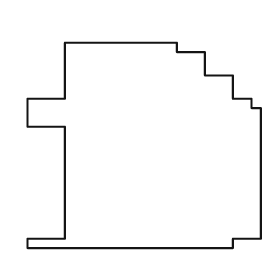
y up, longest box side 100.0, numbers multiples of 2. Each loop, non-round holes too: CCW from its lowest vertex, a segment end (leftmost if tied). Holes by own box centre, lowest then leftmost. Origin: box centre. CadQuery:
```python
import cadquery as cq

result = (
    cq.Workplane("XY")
    .moveTo(-50.0, -44.0)
    .lineTo(38.0, -44.0)
    .lineTo(38.0, -40.0)
    .lineTo(50.0, -40.0)
    .lineTo(50.0, 16.0)
    .lineTo(46.0, 16.0)
    .lineTo(46.0, 20.0)
    .lineTo(38.0, 20.0)
    .lineTo(38.0, 30.0)
    .lineTo(26.0, 30.0)
    .lineTo(26.0, 40.0)
    .lineTo(14.0, 40.0)
    .lineTo(14.0, 44.0)
    .lineTo(-34.0, 44.0)
    .lineTo(-34.0, 20.0)
    .lineTo(-50.0, 20.0)
    .lineTo(-50.0, 8.0)
    .lineTo(-34.0, 8.0)
    .lineTo(-34.0, -40.0)
    .lineTo(-50.0, -40.0)
    .close()
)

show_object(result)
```